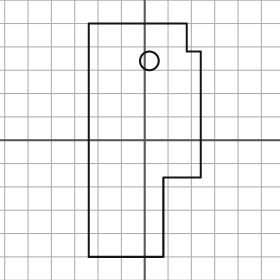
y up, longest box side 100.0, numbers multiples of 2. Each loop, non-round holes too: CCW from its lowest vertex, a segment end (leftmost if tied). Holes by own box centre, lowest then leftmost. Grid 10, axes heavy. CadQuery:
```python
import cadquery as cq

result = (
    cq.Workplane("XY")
    .moveTo(-24.0, -50.0)
    .lineTo(8.0, -50.0)
    .lineTo(8.0, -16.0)
    .lineTo(24.0, -16.0)
    .lineTo(24.0, 38.0)
    .lineTo(18.0, 38.0)
    .lineTo(18.0, 50.0)
    .lineTo(-24.0, 50.0)
    .close()
    .moveTo(2.0, 34.0)
    .circle(4.0)
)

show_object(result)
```